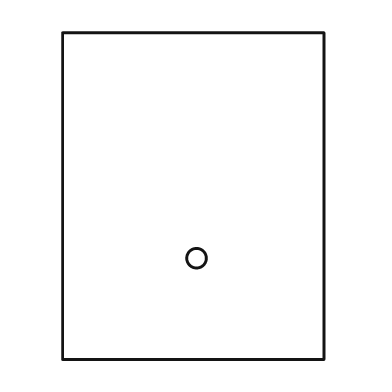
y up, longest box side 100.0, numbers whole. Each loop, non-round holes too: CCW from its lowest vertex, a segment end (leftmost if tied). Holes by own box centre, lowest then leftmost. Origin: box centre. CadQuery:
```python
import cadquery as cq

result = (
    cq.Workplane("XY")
    .moveTo(-40.0, -50.0)
    .lineTo(40.0, -50.0)
    .lineTo(40.0, 50.0)
    .lineTo(-40.0, 50.0)
    .close()
    .moveTo(1.0, -19.0)
    .circle(3.0)
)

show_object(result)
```